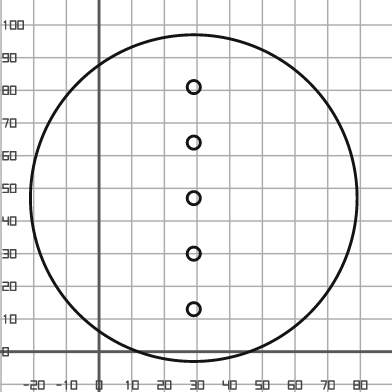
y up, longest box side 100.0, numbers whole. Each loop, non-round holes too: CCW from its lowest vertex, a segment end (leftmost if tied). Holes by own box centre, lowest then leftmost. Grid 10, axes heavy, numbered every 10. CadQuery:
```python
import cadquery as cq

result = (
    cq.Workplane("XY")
    .moveTo(29.0, 47.0)
    .circle(50.0)
    .moveTo(29.0, 13.0)
    .circle(2.0)
    .moveTo(29.0, 30.0)
    .circle(2.0)
    .moveTo(29.0, 47.0)
    .circle(2.0)
    .moveTo(29.0, 64.0)
    .circle(2.0)
    .moveTo(29.0, 81.0)
    .circle(2.0)
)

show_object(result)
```